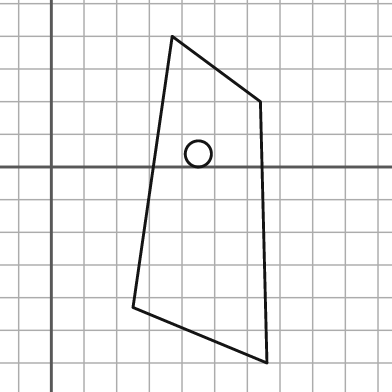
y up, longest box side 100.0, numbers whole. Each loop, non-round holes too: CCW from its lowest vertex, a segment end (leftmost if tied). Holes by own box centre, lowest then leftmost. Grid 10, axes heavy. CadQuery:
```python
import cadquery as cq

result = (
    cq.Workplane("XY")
    .moveTo(66.0, -60.0)
    .lineTo(64.0, 20.0)
    .lineTo(37.0, 40.0)
    .lineTo(25.0, -43.0)
    .close()
    .moveTo(45.0, 4.0)
    .circle(4.0)
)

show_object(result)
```